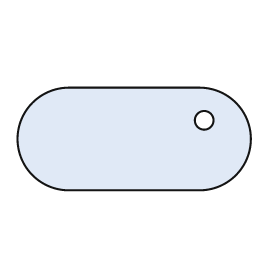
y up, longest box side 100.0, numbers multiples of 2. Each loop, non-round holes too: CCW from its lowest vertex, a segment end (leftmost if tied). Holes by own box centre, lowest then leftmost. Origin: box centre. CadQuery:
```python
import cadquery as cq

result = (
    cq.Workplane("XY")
    .moveTo(-28.0, -22.0)
    .lineTo(28.0, -22.0)
    .threePointArc((50.0, 0.0), (28.0, 22.0))
    .lineTo(-28.0, 22.0)
    .threePointArc((-50.0, 0.0), (-28.0, -22.0))
    .close()
    .moveTo(30.0, 8.0)
    .circle(4.0)
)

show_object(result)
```